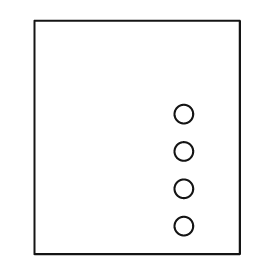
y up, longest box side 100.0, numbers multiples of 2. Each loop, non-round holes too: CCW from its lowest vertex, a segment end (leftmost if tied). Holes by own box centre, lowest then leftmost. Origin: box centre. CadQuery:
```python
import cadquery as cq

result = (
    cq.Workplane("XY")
    .moveTo(-44.0, -50.0)
    .lineTo(44.0, -50.0)
    .lineTo(44.0, 50.0)
    .lineTo(-44.0, 50.0)
    .close()
    .moveTo(20.0, -38.0)
    .circle(4.0)
    .moveTo(20.0, -22.0)
    .circle(4.0)
    .moveTo(20.0, -6.0)
    .circle(4.0)
    .moveTo(20.0, 10.0)
    .circle(4.0)
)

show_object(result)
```